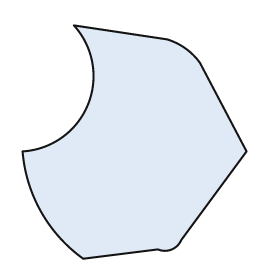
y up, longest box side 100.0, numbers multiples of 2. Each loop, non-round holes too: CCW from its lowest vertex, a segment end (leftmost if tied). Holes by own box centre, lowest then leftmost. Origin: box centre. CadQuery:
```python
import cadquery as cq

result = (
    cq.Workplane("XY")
    .moveTo(-22.0, -50.0)
    .lineTo(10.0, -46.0)
    .threePointArc((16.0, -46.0), (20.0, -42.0))
    .lineTo(48.0, -4.0)
    .lineTo(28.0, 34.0)
    .threePointArc((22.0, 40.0), (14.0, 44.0))
    .lineTo(-26.0, 50.0)
    .threePointArc((-20.0, 16.0), (-48.0, -4.0))
    .threePointArc((-40.0, -30.0), (-22.0, -50.0))
    .close()
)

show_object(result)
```